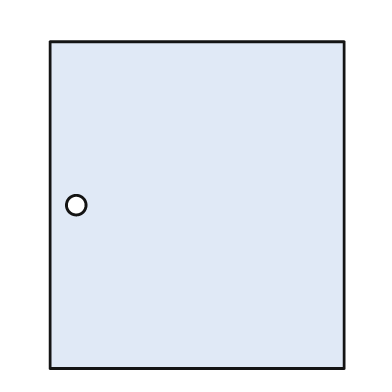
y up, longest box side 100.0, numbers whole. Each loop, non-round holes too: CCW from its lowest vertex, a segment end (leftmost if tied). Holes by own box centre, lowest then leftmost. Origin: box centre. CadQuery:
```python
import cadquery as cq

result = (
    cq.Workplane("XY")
    .moveTo(-45.0, -50.0)
    .lineTo(45.0, -50.0)
    .lineTo(45.0, 50.0)
    .lineTo(-45.0, 50.0)
    .close()
    .moveTo(-37.0, 0.0)
    .circle(3.0)
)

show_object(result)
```